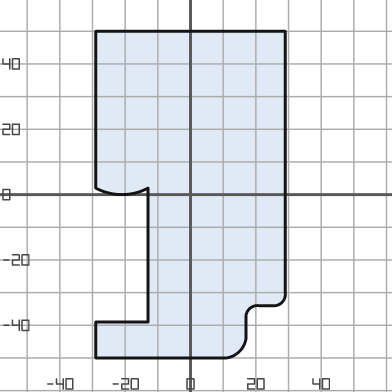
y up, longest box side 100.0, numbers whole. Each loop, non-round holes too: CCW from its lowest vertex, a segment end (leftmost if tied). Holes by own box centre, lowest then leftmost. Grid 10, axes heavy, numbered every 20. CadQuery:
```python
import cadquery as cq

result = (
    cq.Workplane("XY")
    .moveTo(-29.0, -50.0)
    .lineTo(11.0, -50.0)
    .threePointArc((15.0, -48.0), (17.0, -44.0))
    .lineTo(17.0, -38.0)
    .threePointArc((18.0, -35.0), (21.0, -34.0))
    .lineTo(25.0, -34.0)
    .threePointArc((28.0, -33.0), (29.0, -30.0))
    .lineTo(29.0, 50.0)
    .lineTo(-29.0, 50.0)
    .lineTo(-29.0, 2.0)
    .threePointArc((-21.0, 0.0), (-13.0, 2.0))
    .lineTo(-13.0, -39.0)
    .lineTo(-29.0, -39.0)
    .close()
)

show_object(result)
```